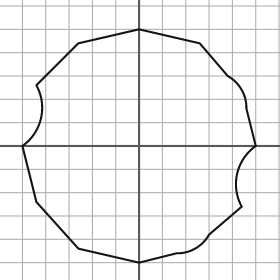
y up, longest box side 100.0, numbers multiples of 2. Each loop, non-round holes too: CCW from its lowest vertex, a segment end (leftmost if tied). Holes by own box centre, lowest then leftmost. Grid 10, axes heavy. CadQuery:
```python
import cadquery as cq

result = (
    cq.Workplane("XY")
    .moveTo(0.0, -50.0)
    .lineTo(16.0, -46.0)
    .threePointArc((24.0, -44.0), (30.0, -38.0))
    .lineTo(44.0, -26.0)
    .threePointArc((42.0, -12.0), (50.0, 0.0))
    .lineTo(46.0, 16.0)
    .threePointArc((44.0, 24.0), (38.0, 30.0))
    .lineTo(26.0, 44.0)
    .lineTo(0.0, 50.0)
    .lineTo(-26.0, 44.0)
    .lineTo(-44.0, 26.0)
    .threePointArc((-42.0, 12.0), (-50.0, 0.0))
    .lineTo(-44.0, -24.0)
    .lineTo(-26.0, -44.0)
    .close()
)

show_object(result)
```